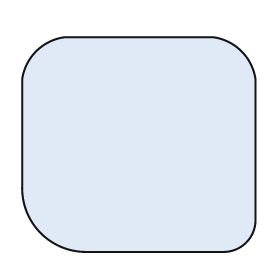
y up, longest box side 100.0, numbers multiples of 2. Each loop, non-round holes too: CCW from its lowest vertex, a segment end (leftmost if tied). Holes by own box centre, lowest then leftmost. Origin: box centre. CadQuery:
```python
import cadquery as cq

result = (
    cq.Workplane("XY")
    .moveTo(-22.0, -46.0)
    .lineTo(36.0, -46.0)
    .threePointArc((46.0, -42.0), (50.0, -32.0))
    .lineTo(50.0, 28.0)
    .threePointArc((44.0, 40.0), (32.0, 46.0))
    .lineTo(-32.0, 46.0)
    .threePointArc((-44.0, 40.0), (-50.0, 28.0))
    .lineTo(-50.0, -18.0)
    .threePointArc((-42.0, -38.0), (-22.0, -46.0))
    .close()
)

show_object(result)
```